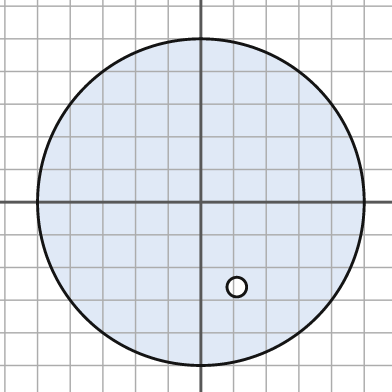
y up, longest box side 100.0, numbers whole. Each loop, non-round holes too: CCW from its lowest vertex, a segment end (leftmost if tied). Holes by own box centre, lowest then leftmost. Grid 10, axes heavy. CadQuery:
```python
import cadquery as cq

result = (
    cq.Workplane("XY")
    .moveTo(0.0, 0.0)
    .circle(50.0)
    .moveTo(11.0, -26.0)
    .circle(3.0)
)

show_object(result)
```